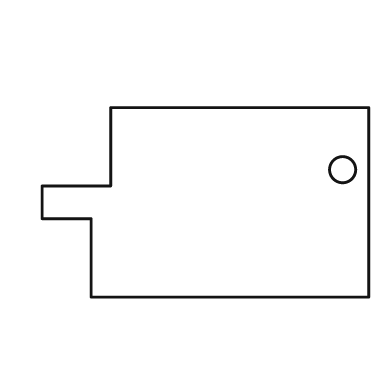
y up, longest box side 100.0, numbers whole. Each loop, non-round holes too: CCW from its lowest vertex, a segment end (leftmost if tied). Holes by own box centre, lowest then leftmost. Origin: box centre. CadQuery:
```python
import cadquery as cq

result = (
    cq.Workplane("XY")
    .moveTo(-35.0, -29.0)
    .lineTo(50.0, -29.0)
    .lineTo(50.0, 29.0)
    .lineTo(-29.0, 29.0)
    .lineTo(-29.0, 5.0)
    .lineTo(-50.0, 5.0)
    .lineTo(-50.0, -5.0)
    .lineTo(-35.0, -5.0)
    .close()
    .moveTo(42.0, 10.0)
    .circle(4.0)
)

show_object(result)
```